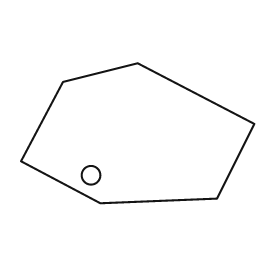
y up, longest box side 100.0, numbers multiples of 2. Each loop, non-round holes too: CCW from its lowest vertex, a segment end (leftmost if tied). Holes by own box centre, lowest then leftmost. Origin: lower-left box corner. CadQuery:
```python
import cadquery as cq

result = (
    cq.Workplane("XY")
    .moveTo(34.0, 0.0)
    .lineTo(84.0, 2.0)
    .lineTo(100.0, 34.0)
    .lineTo(50.0, 60.0)
    .lineTo(18.0, 52.0)
    .lineTo(0.0, 18.0)
    .close()
    .moveTo(30.0, 12.0)
    .circle(4.0)
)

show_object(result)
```